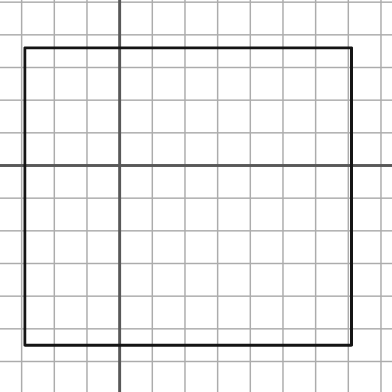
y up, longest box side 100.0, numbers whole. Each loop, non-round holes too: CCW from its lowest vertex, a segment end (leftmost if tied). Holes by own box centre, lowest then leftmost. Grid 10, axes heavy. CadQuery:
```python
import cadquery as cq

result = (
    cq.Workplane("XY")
    .moveTo(-29.0, -55.0)
    .lineTo(71.0, -55.0)
    .lineTo(71.0, 36.0)
    .lineTo(-29.0, 36.0)
    .close()
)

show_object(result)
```